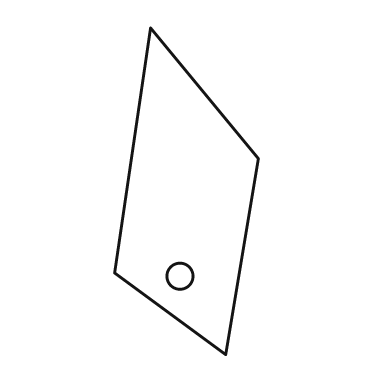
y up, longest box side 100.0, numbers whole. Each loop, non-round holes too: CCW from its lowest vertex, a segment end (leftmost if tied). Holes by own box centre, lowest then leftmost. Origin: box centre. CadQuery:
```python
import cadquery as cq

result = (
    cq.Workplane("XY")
    .moveTo(12.0, -50.0)
    .lineTo(22.0, 10.0)
    .lineTo(-11.0, 50.0)
    .lineTo(-22.0, -25.0)
    .close()
    .moveTo(-2.0, -26.0)
    .circle(4.0)
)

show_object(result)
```